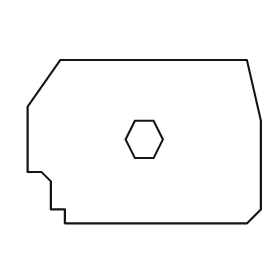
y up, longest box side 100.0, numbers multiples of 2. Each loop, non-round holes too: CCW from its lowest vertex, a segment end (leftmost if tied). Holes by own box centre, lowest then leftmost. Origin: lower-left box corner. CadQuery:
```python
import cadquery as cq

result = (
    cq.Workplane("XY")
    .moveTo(16.0, 0.0)
    .lineTo(94.0, 0.0)
    .lineTo(100.0, 6.0)
    .lineTo(100.0, 44.0)
    .lineTo(94.0, 70.0)
    .lineTo(14.0, 70.0)
    .lineTo(0.0, 50.0)
    .lineTo(0.0, 22.0)
    .lineTo(6.0, 22.0)
    .lineTo(10.0, 18.0)
    .lineTo(10.0, 6.0)
    .lineTo(16.0, 6.0)
    .close()
    .moveTo(46.0, 28.0)
    .lineTo(54.0, 28.0)
    .lineTo(58.0, 36.0)
    .lineTo(54.0, 44.0)
    .lineTo(46.0, 44.0)
    .lineTo(42.0, 36.0)
    .close()
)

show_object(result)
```